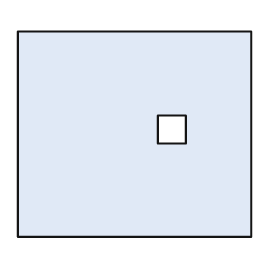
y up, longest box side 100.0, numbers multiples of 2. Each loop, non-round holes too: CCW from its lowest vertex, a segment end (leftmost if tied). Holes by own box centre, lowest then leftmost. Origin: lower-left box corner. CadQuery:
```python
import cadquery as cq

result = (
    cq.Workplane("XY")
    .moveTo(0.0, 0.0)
    .lineTo(100.0, 0.0)
    .lineTo(100.0, 88.0)
    .lineTo(0.0, 88.0)
    .close()
    .moveTo(60.0, 40.0)
    .lineTo(72.0, 40.0)
    .lineTo(72.0, 52.0)
    .lineTo(60.0, 52.0)
    .close()
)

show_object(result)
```